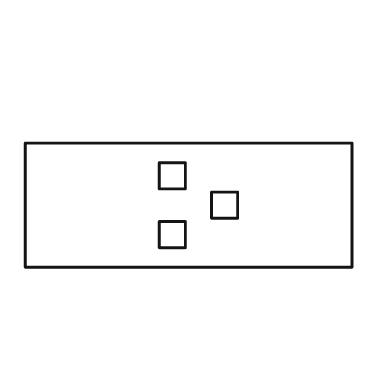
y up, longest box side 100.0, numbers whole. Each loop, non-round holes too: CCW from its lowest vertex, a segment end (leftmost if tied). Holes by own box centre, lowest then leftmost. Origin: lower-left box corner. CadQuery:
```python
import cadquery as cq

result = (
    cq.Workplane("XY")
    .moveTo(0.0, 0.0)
    .lineTo(100.0, 0.0)
    .lineTo(100.0, 38.0)
    .lineTo(0.0, 38.0)
    .close()
    .moveTo(41.0, 6.0)
    .lineTo(49.0, 6.0)
    .lineTo(49.0, 14.0)
    .lineTo(41.0, 14.0)
    .close()
    .moveTo(57.0, 15.0)
    .lineTo(65.0, 15.0)
    .lineTo(65.0, 23.0)
    .lineTo(57.0, 23.0)
    .close()
    .moveTo(41.0, 24.0)
    .lineTo(49.0, 24.0)
    .lineTo(49.0, 32.0)
    .lineTo(41.0, 32.0)
    .close()
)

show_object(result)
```